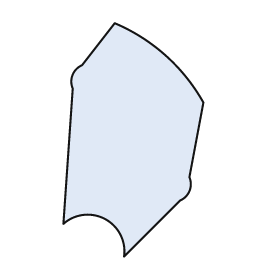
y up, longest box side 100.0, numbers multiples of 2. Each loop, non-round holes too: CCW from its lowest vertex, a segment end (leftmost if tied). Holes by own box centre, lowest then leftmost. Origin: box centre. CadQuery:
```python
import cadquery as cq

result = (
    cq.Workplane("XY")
    .moveTo(-4.0, -50.0)
    .lineTo(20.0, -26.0)
    .threePointArc((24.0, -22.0), (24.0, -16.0))
    .lineTo(30.0, 16.0)
    .threePointArc((14.0, 36.0), (-8.0, 50.0))
    .lineTo(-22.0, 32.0)
    .threePointArc((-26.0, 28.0), (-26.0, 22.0))
    .lineTo(-30.0, -36.0)
    .threePointArc((-12.0, -34.0), (-4.0, -50.0))
    .close()
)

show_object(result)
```